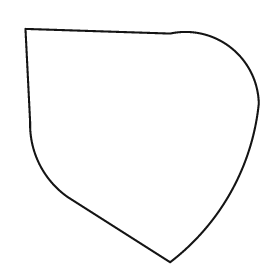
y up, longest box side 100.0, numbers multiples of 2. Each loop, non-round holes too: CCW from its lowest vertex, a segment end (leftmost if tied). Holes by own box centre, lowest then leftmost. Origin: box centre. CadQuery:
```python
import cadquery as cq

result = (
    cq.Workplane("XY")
    .moveTo(12.0, -50.0)
    .threePointArc((38.0, -20.0), (50.0, 18.0))
    .threePointArc((38.0, 42.0), (12.0, 48.0))
    .lineTo(-50.0, 50.0)
    .lineTo(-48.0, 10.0)
    .threePointArc((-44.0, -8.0), (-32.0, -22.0))
    .close()
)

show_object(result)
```